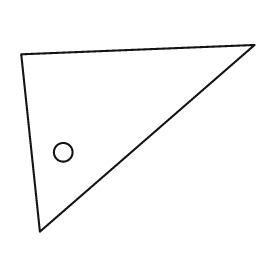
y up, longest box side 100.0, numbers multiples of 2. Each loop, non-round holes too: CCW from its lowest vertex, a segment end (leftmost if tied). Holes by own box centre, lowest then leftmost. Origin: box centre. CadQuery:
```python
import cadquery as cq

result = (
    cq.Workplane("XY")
    .moveTo(-42.0, -40.0)
    .lineTo(50.0, 40.0)
    .lineTo(-50.0, 36.0)
    .close()
    .moveTo(-32.0, -6.0)
    .circle(4.0)
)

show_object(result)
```